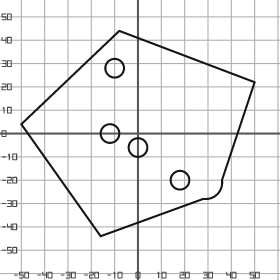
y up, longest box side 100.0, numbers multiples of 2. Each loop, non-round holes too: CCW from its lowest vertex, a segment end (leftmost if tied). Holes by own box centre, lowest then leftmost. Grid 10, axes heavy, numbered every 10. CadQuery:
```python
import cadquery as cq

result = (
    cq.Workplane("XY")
    .moveTo(-16.0, -44.0)
    .lineTo(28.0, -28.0)
    .threePointArc((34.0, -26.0), (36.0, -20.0))
    .lineTo(50.0, 22.0)
    .lineTo(-8.0, 44.0)
    .lineTo(-50.0, 4.0)
    .close()
    .moveTo(18.0, -20.0)
    .circle(4.0)
    .moveTo(0.0, -6.0)
    .circle(4.0)
    .moveTo(-12.0, 0.0)
    .circle(4.0)
    .moveTo(-10.0, 28.0)
    .circle(4.0)
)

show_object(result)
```